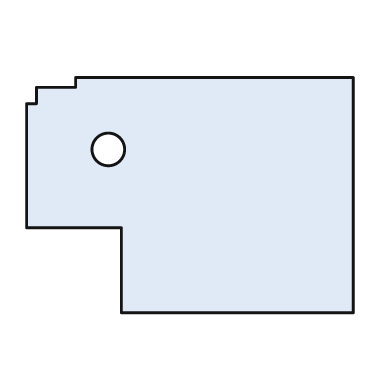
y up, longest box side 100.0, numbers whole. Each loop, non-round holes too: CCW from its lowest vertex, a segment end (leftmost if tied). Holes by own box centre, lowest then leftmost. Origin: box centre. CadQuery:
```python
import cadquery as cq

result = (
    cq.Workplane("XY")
    .moveTo(-21.0, -36.0)
    .lineTo(50.0, -36.0)
    .lineTo(50.0, 36.0)
    .lineTo(-35.0, 36.0)
    .lineTo(-35.0, 33.0)
    .lineTo(-47.0, 33.0)
    .lineTo(-47.0, 28.0)
    .lineTo(-50.0, 28.0)
    .lineTo(-50.0, -10.0)
    .lineTo(-21.0, -10.0)
    .close()
    .moveTo(-25.0, 14.0)
    .circle(5.0)
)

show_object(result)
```